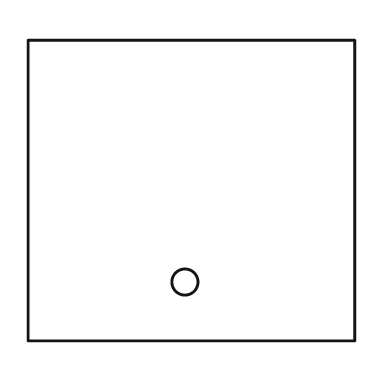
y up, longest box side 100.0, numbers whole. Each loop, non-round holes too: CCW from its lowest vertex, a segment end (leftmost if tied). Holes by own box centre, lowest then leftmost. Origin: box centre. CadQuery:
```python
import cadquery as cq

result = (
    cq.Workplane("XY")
    .moveTo(-50.0, -46.0)
    .lineTo(50.0, -46.0)
    .lineTo(50.0, 46.0)
    .lineTo(-50.0, 46.0)
    .close()
    .moveTo(-2.0, -28.0)
    .circle(4.0)
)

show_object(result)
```